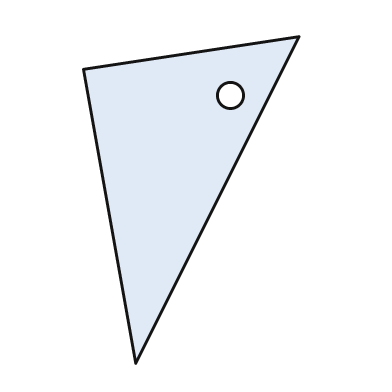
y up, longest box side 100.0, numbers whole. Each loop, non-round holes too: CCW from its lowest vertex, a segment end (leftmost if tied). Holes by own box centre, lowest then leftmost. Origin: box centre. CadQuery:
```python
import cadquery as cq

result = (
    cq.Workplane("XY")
    .moveTo(-17.0, -50.0)
    .lineTo(33.0, 50.0)
    .lineTo(-33.0, 40.0)
    .close()
    .moveTo(12.0, 32.0)
    .circle(4.0)
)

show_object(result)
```